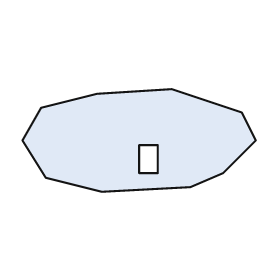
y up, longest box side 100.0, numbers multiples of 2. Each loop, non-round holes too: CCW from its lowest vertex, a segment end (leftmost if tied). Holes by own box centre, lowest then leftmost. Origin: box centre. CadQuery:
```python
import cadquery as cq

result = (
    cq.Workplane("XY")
    .moveTo(-16.0, -22.0)
    .lineTo(22.0, -20.0)
    .lineTo(36.0, -14.0)
    .lineTo(50.0, 0.0)
    .lineTo(44.0, 12.0)
    .lineTo(14.0, 22.0)
    .lineTo(-18.0, 20.0)
    .lineTo(-42.0, 14.0)
    .lineTo(-50.0, 0.0)
    .lineTo(-40.0, -16.0)
    .close()
    .moveTo(0.0, -14.0)
    .lineTo(8.0, -14.0)
    .lineTo(8.0, -2.0)
    .lineTo(0.0, -2.0)
    .close()
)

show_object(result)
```